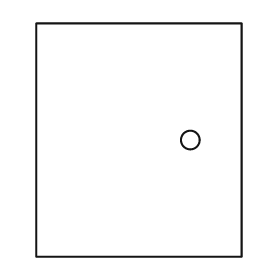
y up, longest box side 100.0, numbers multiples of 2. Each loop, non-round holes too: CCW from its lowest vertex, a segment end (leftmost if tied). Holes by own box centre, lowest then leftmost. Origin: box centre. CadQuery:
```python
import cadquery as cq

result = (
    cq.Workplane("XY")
    .moveTo(-44.0, -50.0)
    .lineTo(44.0, -50.0)
    .lineTo(44.0, 50.0)
    .lineTo(-44.0, 50.0)
    .close()
    .moveTo(22.0, 0.0)
    .circle(4.0)
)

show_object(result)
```